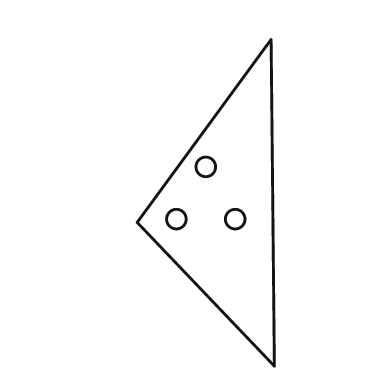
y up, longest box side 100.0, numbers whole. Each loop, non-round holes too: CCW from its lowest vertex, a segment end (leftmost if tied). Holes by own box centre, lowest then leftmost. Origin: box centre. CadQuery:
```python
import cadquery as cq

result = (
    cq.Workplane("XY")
    .moveTo(21.0, -50.0)
    .lineTo(20.0, 50.0)
    .lineTo(-21.0, -6.0)
    .close()
    .moveTo(-9.0, -5.0)
    .circle(3.0)
    .moveTo(9.0, -5.0)
    .circle(3.0)
    .moveTo(0.0, 11.0)
    .circle(3.0)
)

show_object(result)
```